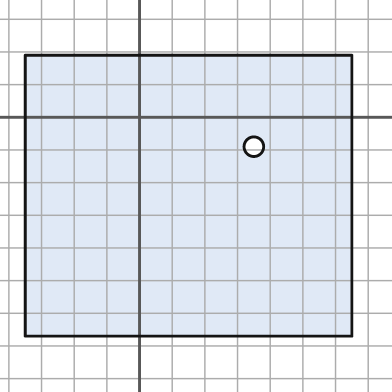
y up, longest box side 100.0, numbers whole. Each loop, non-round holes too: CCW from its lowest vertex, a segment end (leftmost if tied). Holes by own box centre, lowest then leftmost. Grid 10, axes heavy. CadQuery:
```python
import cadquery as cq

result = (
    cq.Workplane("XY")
    .moveTo(-35.0, -67.0)
    .lineTo(65.0, -67.0)
    .lineTo(65.0, 19.0)
    .lineTo(-35.0, 19.0)
    .close()
    .moveTo(35.0, -9.0)
    .circle(3.0)
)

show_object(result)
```